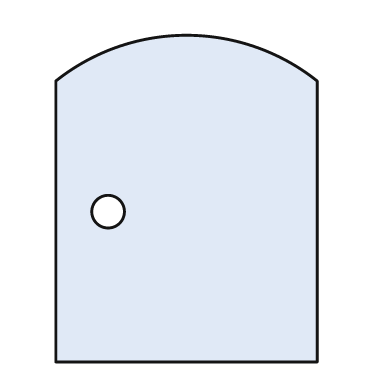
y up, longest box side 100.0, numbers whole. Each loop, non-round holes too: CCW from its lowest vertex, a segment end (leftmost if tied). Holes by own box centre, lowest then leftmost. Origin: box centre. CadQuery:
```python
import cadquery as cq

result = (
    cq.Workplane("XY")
    .moveTo(-40.0, -50.0)
    .lineTo(40.0, -50.0)
    .lineTo(40.0, 36.0)
    .threePointArc((0.0, 50.0), (-40.0, 36.0))
    .close()
    .moveTo(-24.0, -4.0)
    .circle(5.0)
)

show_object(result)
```